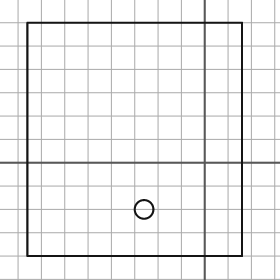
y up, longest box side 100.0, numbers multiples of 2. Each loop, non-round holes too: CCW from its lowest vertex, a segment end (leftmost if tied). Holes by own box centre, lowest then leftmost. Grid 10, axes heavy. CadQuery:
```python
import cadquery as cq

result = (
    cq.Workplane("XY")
    .moveTo(-76.0, -40.0)
    .lineTo(16.0, -40.0)
    .lineTo(16.0, 60.0)
    .lineTo(-76.0, 60.0)
    .close()
    .moveTo(-26.0, -20.0)
    .circle(4.0)
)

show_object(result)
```